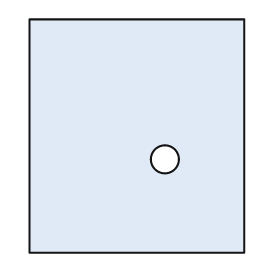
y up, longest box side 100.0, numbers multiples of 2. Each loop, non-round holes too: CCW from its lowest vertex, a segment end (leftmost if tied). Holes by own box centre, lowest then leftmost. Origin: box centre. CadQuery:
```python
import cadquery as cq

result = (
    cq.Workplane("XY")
    .moveTo(-46.0, -50.0)
    .lineTo(46.0, -50.0)
    .lineTo(46.0, 50.0)
    .lineTo(-46.0, 50.0)
    .close()
    .moveTo(12.0, -10.0)
    .circle(6.0)
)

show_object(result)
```